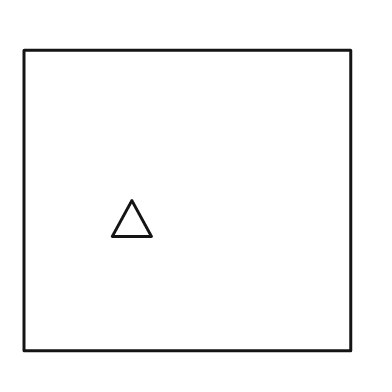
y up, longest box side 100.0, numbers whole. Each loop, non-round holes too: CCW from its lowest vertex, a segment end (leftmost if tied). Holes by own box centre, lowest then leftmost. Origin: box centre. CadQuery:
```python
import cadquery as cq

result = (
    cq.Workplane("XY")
    .moveTo(-50.0, -46.0)
    .lineTo(50.0, -46.0)
    .lineTo(50.0, 46.0)
    .lineTo(-50.0, 46.0)
    .close()
    .moveTo(-23.0, -11.0)
    .lineTo(-11.0, -11.0)
    .lineTo(-17.0, 0.0)
    .close()
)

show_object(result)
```